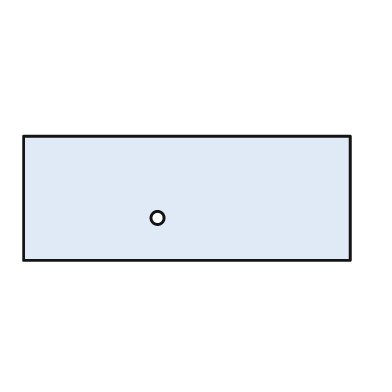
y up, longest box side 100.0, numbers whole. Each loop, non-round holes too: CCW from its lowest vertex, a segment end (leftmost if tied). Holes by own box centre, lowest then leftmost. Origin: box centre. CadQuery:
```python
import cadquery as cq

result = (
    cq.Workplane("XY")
    .moveTo(-50.0, -19.0)
    .lineTo(50.0, -19.0)
    .lineTo(50.0, 19.0)
    .lineTo(-50.0, 19.0)
    .close()
    .moveTo(-9.0, -6.0)
    .circle(2.0)
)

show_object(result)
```